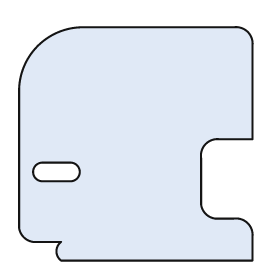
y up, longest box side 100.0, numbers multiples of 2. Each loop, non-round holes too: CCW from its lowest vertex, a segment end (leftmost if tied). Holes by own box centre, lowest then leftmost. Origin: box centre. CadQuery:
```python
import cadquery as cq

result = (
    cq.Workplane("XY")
    .moveTo(-32.0, -50.0)
    .lineTo(50.0, -50.0)
    .lineTo(50.0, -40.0)
    .threePointArc((48.0, -34.0), (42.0, -32.0))
    .lineTo(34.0, -32.0)
    .threePointArc((30.0, -30.0), (28.0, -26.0))
    .lineTo(28.0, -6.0)
    .threePointArc((30.0, 0.0), (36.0, 2.0))
    .lineTo(50.0, 2.0)
    .lineTo(50.0, 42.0)
    .threePointArc((48.0, 48.0), (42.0, 50.0))
    .lineTo(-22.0, 50.0)
    .threePointArc((-42.0, 42.0), (-50.0, 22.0))
    .lineTo(-50.0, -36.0)
    .threePointArc((-48.0, -40.0), (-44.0, -42.0))
    .lineTo(-32.0, -42.0)
    .threePointArc((-34.0, -46.0), (-32.0, -50.0))
    .close()
    .moveTo(-40.0, -16.0)
    .lineTo(-28.0, -16.0)
    .threePointArc((-24.0, -12.0), (-28.0, -8.0))
    .lineTo(-40.0, -8.0)
    .threePointArc((-44.0, -12.0), (-40.0, -16.0))
    .close()
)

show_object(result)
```